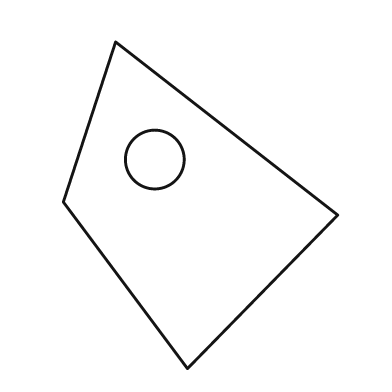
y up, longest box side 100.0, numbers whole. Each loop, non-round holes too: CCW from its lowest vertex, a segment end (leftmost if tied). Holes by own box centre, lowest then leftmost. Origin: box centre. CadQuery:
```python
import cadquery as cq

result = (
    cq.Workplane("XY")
    .moveTo(-4.0, -50.0)
    .lineTo(42.0, -3.0)
    .lineTo(-26.0, 50.0)
    .lineTo(-42.0, 1.0)
    .close()
    .moveTo(-14.0, 14.0)
    .circle(9.0)
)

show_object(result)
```